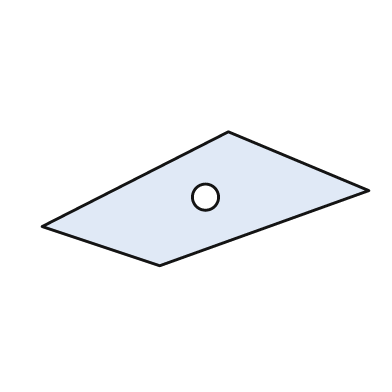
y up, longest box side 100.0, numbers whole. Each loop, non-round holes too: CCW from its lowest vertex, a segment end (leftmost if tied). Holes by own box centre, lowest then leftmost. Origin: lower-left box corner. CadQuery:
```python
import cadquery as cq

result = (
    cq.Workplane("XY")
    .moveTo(36.0, 0.0)
    .lineTo(100.0, 23.0)
    .lineTo(57.0, 41.0)
    .lineTo(0.0, 12.0)
    .close()
    .moveTo(50.0, 21.0)
    .circle(4.0)
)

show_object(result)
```